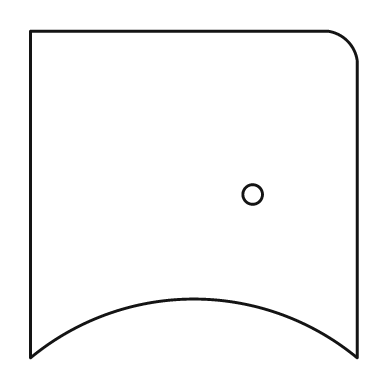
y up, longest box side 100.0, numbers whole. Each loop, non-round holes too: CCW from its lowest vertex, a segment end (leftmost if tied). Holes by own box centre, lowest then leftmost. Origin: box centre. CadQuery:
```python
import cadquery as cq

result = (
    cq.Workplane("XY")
    .moveTo(-50.0, -50.0)
    .threePointArc((0.0, -32.0), (50.0, -50.0))
    .lineTo(50.0, 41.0)
    .threePointArc((47.0, 47.0), (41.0, 50.0))
    .lineTo(-50.0, 50.0)
    .close()
    .moveTo(18.0, 0.0)
    .circle(3.0)
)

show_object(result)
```